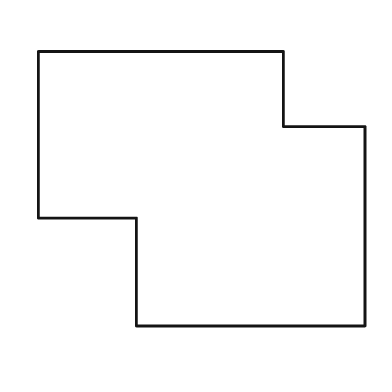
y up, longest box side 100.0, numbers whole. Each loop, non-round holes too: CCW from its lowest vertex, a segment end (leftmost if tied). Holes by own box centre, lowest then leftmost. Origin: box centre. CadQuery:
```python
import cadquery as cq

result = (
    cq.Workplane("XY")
    .moveTo(-20.0, -42.0)
    .lineTo(50.0, -42.0)
    .lineTo(50.0, 19.0)
    .lineTo(25.0, 19.0)
    .lineTo(25.0, 42.0)
    .lineTo(-50.0, 42.0)
    .lineTo(-50.0, -9.0)
    .lineTo(-20.0, -9.0)
    .close()
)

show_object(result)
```